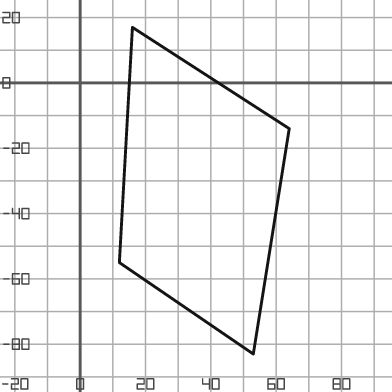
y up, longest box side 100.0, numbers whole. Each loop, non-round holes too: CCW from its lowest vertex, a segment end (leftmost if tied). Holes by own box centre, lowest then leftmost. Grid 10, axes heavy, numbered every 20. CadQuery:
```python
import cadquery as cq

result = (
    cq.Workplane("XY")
    .moveTo(53.0, -83.0)
    .lineTo(64.0, -14.0)
    .lineTo(16.0, 17.0)
    .lineTo(12.0, -55.0)
    .close()
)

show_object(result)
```